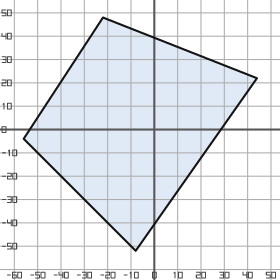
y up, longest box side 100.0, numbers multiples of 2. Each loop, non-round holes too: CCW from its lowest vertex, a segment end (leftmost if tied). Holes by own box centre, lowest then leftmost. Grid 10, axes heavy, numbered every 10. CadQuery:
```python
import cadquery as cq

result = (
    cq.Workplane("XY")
    .moveTo(-8.0, -52.0)
    .lineTo(44.0, 22.0)
    .lineTo(-22.0, 48.0)
    .lineTo(-56.0, -4.0)
    .close()
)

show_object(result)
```